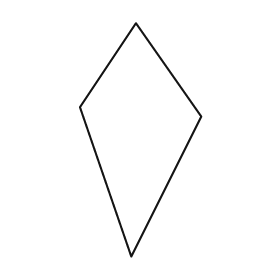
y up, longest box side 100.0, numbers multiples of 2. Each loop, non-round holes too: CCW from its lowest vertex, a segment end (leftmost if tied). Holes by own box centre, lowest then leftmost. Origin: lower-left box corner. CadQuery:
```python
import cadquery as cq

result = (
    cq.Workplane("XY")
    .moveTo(22.0, 0.0)
    .lineTo(52.0, 60.0)
    .lineTo(24.0, 100.0)
    .lineTo(0.0, 64.0)
    .close()
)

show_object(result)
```